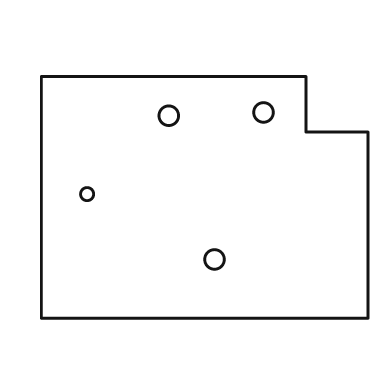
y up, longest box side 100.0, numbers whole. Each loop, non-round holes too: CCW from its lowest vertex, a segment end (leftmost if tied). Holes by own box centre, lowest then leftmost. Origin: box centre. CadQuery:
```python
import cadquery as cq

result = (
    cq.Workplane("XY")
    .moveTo(-50.0, -37.0)
    .lineTo(50.0, -37.0)
    .lineTo(50.0, 20.0)
    .lineTo(31.0, 20.0)
    .lineTo(31.0, 37.0)
    .lineTo(-50.0, 37.0)
    .close()
    .moveTo(3.0, -19.0)
    .circle(3.0)
    .moveTo(-36.0, 1.0)
    .circle(2.0)
    .moveTo(-11.0, 25.0)
    .circle(3.0)
    .moveTo(18.0, 26.0)
    .circle(3.0)
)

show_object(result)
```